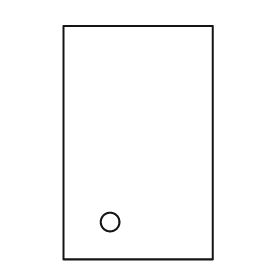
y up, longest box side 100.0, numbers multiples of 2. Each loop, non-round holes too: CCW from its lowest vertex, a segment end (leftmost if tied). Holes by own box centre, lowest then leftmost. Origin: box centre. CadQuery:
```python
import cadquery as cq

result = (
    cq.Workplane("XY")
    .moveTo(-32.0, -50.0)
    .lineTo(32.0, -50.0)
    .lineTo(32.0, 50.0)
    .lineTo(-32.0, 50.0)
    .close()
    .moveTo(-12.0, -34.0)
    .circle(4.0)
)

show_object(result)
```